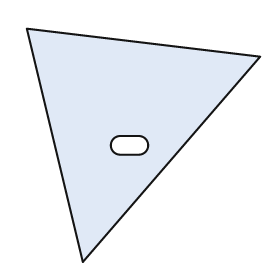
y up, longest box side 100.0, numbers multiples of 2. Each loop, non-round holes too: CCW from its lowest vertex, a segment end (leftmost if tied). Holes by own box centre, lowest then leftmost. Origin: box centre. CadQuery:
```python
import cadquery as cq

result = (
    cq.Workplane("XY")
    .moveTo(-26.0, -50.0)
    .lineTo(50.0, 38.0)
    .lineTo(-50.0, 50.0)
    .close()
    .moveTo(-10.0, -4.0)
    .lineTo(-2.0, -4.0)
    .threePointArc((2.0, 0.0), (-2.0, 4.0))
    .lineTo(-10.0, 4.0)
    .threePointArc((-14.0, 0.0), (-10.0, -4.0))
    .close()
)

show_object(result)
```